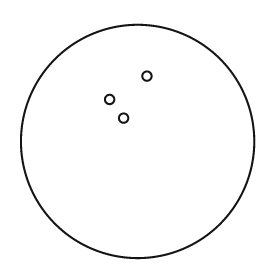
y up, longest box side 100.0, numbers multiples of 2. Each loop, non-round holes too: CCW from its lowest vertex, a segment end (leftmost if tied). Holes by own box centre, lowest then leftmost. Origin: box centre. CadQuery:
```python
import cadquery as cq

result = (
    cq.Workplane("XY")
    .moveTo(0.0, 0.0)
    .circle(50.0)
    .moveTo(-6.0, 10.0)
    .circle(2.0)
    .moveTo(-12.0, 18.0)
    .circle(2.0)
    .moveTo(4.0, 28.0)
    .circle(2.0)
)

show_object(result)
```